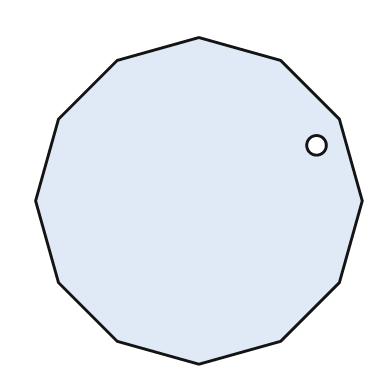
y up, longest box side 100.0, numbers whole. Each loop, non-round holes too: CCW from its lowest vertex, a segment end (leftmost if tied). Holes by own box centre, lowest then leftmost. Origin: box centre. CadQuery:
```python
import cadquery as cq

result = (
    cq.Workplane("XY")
    .moveTo(0.0, -50.0)
    .lineTo(25.0, -43.0)
    .lineTo(43.0, -25.0)
    .lineTo(50.0, 0.0)
    .lineTo(43.0, 25.0)
    .lineTo(25.0, 43.0)
    .lineTo(0.0, 50.0)
    .lineTo(-25.0, 43.0)
    .lineTo(-43.0, 25.0)
    .lineTo(-50.0, 0.0)
    .lineTo(-43.0, -25.0)
    .lineTo(-25.0, -43.0)
    .close()
    .moveTo(36.0, 17.0)
    .circle(3.0)
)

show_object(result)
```